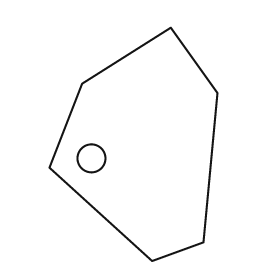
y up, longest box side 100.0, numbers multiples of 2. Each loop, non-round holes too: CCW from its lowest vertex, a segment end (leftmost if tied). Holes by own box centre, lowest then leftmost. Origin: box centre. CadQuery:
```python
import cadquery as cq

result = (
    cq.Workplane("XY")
    .moveTo(8.0, -50.0)
    .lineTo(30.0, -42.0)
    .lineTo(36.0, 22.0)
    .lineTo(16.0, 50.0)
    .lineTo(-22.0, 26.0)
    .lineTo(-36.0, -10.0)
    .close()
    .moveTo(-18.0, -6.0)
    .circle(6.0)
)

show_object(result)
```